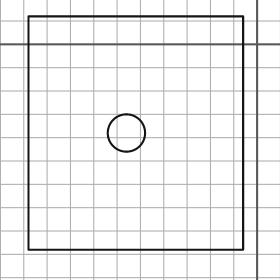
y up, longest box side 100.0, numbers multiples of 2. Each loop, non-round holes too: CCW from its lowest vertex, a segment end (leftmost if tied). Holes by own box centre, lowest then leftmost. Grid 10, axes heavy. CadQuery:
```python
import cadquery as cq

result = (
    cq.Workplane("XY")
    .moveTo(-98.0, -88.0)
    .lineTo(-6.0, -88.0)
    .lineTo(-6.0, 12.0)
    .lineTo(-98.0, 12.0)
    .close()
    .moveTo(-56.0, -38.0)
    .circle(8.0)
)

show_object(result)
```